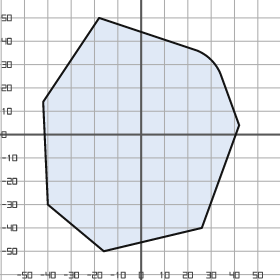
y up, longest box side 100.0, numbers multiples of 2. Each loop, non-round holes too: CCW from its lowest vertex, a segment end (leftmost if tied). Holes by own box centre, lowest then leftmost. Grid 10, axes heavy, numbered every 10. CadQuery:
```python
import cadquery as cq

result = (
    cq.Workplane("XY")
    .moveTo(-16.0, -50.0)
    .lineTo(26.0, -40.0)
    .lineTo(42.0, 4.0)
    .lineTo(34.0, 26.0)
    .threePointArc((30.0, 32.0), (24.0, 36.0))
    .lineTo(-18.0, 50.0)
    .lineTo(-42.0, 14.0)
    .lineTo(-40.0, -30.0)
    .close()
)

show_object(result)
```